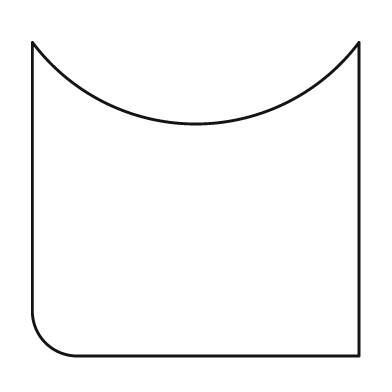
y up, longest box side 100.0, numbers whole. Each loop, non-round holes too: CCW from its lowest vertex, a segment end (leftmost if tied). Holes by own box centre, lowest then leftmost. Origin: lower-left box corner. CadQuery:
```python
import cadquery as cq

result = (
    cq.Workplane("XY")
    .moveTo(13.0, 0.0)
    .lineTo(100.0, 0.0)
    .lineTo(100.0, 96.0)
    .threePointArc((50.0, 71.0), (0.0, 96.0))
    .lineTo(0.0, 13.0)
    .threePointArc((4.0, 4.0), (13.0, 0.0))
    .close()
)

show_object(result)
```